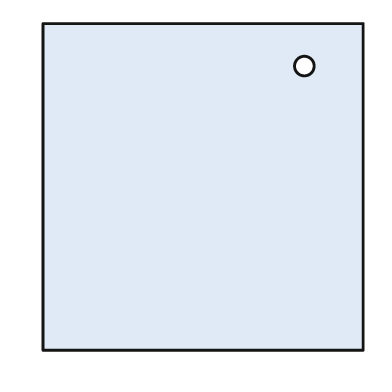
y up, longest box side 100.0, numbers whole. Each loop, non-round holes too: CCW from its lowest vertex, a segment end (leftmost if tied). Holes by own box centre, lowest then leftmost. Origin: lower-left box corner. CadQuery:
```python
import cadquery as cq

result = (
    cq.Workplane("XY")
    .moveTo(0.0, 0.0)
    .lineTo(98.0, 0.0)
    .lineTo(98.0, 100.0)
    .lineTo(0.0, 100.0)
    .close()
    .moveTo(80.0, 87.0)
    .circle(3.0)
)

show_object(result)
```